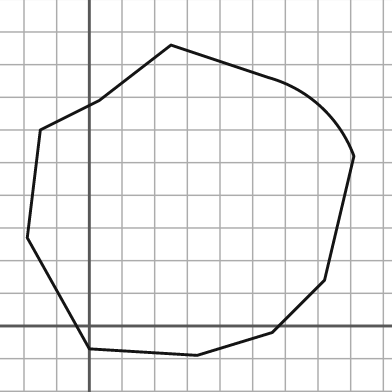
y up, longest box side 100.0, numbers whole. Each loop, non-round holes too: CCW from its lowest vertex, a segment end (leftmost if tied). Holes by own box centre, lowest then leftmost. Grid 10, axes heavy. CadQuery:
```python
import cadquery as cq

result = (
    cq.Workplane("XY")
    .moveTo(33.0, -9.0)
    .lineTo(56.0, -2.0)
    .lineTo(72.0, 14.0)
    .lineTo(81.0, 52.0)
    .threePointArc((71.0, 67.0), (55.0, 76.0))
    .lineTo(25.0, 86.0)
    .lineTo(3.0, 69.0)
    .lineTo(-15.0, 60.0)
    .lineTo(-19.0, 27.0)
    .lineTo(0.0, -7.0)
    .close()
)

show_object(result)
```